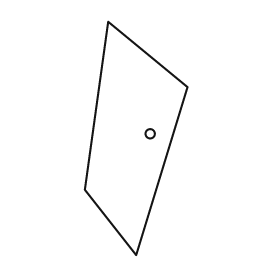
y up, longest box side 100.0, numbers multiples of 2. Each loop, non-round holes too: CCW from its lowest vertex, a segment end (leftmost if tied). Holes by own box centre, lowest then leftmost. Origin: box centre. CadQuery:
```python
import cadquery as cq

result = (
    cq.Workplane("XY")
    .moveTo(0.0, -50.0)
    .lineTo(22.0, 22.0)
    .lineTo(-12.0, 50.0)
    .lineTo(-22.0, -22.0)
    .close()
    .moveTo(6.0, 2.0)
    .circle(2.0)
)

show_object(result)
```